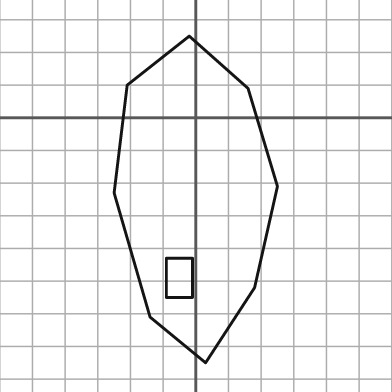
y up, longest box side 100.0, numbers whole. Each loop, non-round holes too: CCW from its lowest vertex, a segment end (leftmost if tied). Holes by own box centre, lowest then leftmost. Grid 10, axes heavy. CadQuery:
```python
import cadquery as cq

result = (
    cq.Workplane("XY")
    .moveTo(3.0, -75.0)
    .lineTo(18.0, -52.0)
    .lineTo(25.0, -21.0)
    .lineTo(16.0, 9.0)
    .lineTo(-2.0, 25.0)
    .lineTo(-21.0, 10.0)
    .lineTo(-25.0, -23.0)
    .lineTo(-14.0, -61.0)
    .close()
    .moveTo(-9.0, -55.0)
    .lineTo(-1.0, -55.0)
    .lineTo(-1.0, -43.0)
    .lineTo(-9.0, -43.0)
    .close()
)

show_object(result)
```